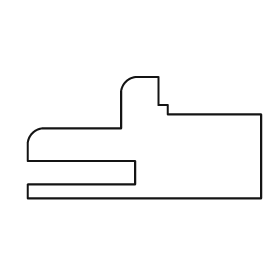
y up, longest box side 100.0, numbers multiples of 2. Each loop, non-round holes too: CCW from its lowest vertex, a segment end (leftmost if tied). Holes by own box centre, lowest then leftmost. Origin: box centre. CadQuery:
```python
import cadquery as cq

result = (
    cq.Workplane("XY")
    .moveTo(-50.0, -26.0)
    .lineTo(50.0, -26.0)
    .lineTo(50.0, 10.0)
    .lineTo(10.0, 10.0)
    .lineTo(10.0, 14.0)
    .lineTo(6.0, 14.0)
    .lineTo(6.0, 26.0)
    .lineTo(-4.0, 26.0)
    .threePointArc((-8.0, 24.0), (-10.0, 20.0))
    .lineTo(-10.0, 4.0)
    .lineTo(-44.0, 4.0)
    .threePointArc((-48.0, 2.0), (-50.0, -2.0))
    .lineTo(-50.0, -10.0)
    .lineTo(-4.0, -10.0)
    .lineTo(-4.0, -20.0)
    .lineTo(-50.0, -20.0)
    .close()
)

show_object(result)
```